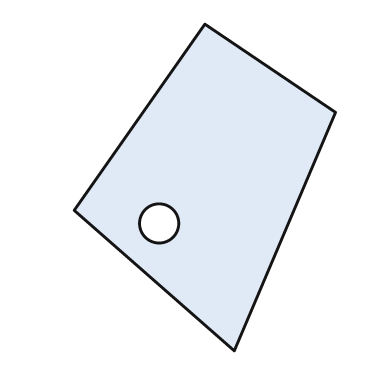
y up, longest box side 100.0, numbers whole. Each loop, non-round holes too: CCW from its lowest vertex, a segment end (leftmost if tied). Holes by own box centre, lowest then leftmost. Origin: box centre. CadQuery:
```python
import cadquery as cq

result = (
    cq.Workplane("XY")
    .moveTo(9.0, -50.0)
    .lineTo(40.0, 23.0)
    .lineTo(0.0, 50.0)
    .lineTo(-40.0, -7.0)
    .close()
    .moveTo(-14.0, -11.0)
    .circle(6.0)
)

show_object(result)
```